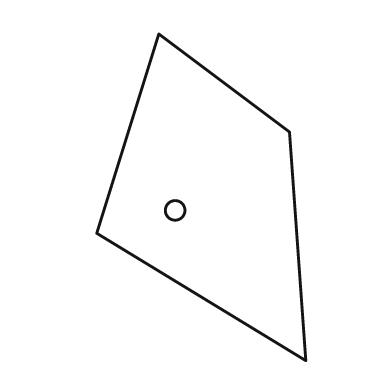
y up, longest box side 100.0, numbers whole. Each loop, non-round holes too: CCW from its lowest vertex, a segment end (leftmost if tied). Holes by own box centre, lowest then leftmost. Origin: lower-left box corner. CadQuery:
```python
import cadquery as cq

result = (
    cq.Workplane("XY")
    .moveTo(64.0, 0.0)
    .lineTo(59.0, 70.0)
    .lineTo(19.0, 100.0)
    .lineTo(0.0, 39.0)
    .close()
    .moveTo(24.0, 46.0)
    .circle(3.0)
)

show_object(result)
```